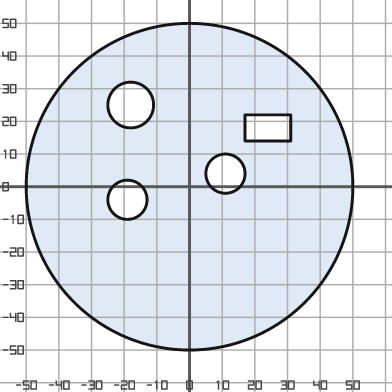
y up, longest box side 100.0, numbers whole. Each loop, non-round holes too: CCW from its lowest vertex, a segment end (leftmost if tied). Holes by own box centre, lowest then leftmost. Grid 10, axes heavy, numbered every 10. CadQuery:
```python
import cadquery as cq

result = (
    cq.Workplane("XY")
    .moveTo(0.0, 0.0)
    .circle(50.0)
    .moveTo(-19.0, -4.0)
    .circle(6.0)
    .moveTo(11.0, 4.0)
    .circle(6.0)
    .moveTo(17.0, 14.0)
    .lineTo(31.0, 14.0)
    .lineTo(31.0, 22.0)
    .lineTo(17.0, 22.0)
    .close()
    .moveTo(-18.0, 25.0)
    .circle(7.0)
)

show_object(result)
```